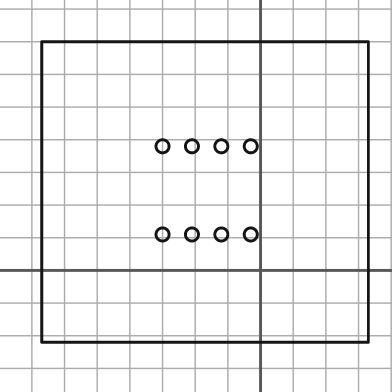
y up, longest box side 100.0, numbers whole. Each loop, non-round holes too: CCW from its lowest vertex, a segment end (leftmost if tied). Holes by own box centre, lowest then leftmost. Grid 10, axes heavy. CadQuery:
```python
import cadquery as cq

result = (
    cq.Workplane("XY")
    .moveTo(-67.0, -22.0)
    .lineTo(33.0, -22.0)
    .lineTo(33.0, 70.0)
    .lineTo(-67.0, 70.0)
    .close()
    .moveTo(-30.0, 11.0)
    .circle(2.0)
    .moveTo(-21.0, 11.0)
    .circle(2.0)
    .moveTo(-12.0, 11.0)
    .circle(2.0)
    .moveTo(-3.0, 11.0)
    .circle(2.0)
    .moveTo(-30.0, 38.0)
    .circle(2.0)
    .moveTo(-21.0, 38.0)
    .circle(2.0)
    .moveTo(-12.0, 38.0)
    .circle(2.0)
    .moveTo(-3.0, 38.0)
    .circle(2.0)
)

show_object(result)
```